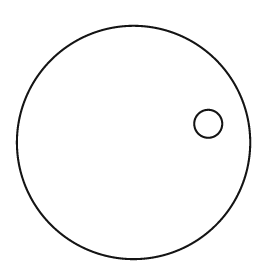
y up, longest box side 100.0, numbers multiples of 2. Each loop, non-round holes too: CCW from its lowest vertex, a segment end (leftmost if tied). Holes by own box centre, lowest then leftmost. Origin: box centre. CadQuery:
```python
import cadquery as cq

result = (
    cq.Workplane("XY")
    .moveTo(0.0, 0.0)
    .circle(50.0)
    .moveTo(32.0, 8.0)
    .circle(6.0)
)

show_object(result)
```